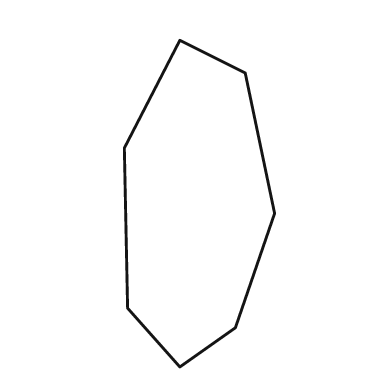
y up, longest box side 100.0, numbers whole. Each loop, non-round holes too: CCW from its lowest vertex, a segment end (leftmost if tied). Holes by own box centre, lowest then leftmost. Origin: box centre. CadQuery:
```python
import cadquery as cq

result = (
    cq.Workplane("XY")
    .moveTo(-6.0, -50.0)
    .lineTo(11.0, -38.0)
    .lineTo(23.0, -3.0)
    .lineTo(14.0, 40.0)
    .lineTo(-6.0, 50.0)
    .lineTo(-23.0, 17.0)
    .lineTo(-22.0, -32.0)
    .close()
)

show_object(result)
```